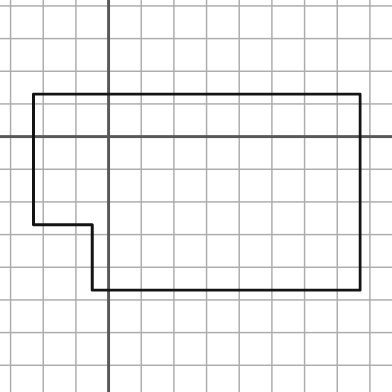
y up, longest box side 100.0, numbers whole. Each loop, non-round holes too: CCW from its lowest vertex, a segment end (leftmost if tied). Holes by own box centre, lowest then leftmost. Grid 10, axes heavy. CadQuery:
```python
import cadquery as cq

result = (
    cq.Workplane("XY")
    .moveTo(-5.0, -47.0)
    .lineTo(77.0, -47.0)
    .lineTo(77.0, 13.0)
    .lineTo(-23.0, 13.0)
    .lineTo(-23.0, -27.0)
    .lineTo(-5.0, -27.0)
    .close()
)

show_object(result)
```